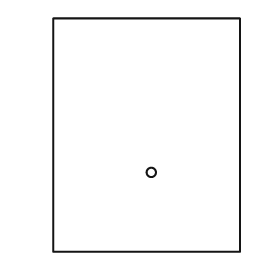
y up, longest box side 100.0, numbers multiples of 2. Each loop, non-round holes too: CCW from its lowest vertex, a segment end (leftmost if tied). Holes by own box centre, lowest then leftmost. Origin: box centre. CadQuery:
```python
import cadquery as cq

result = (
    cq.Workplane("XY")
    .moveTo(-40.0, -50.0)
    .lineTo(40.0, -50.0)
    .lineTo(40.0, 50.0)
    .lineTo(-40.0, 50.0)
    .close()
    .moveTo(2.0, -16.0)
    .circle(2.0)
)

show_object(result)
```